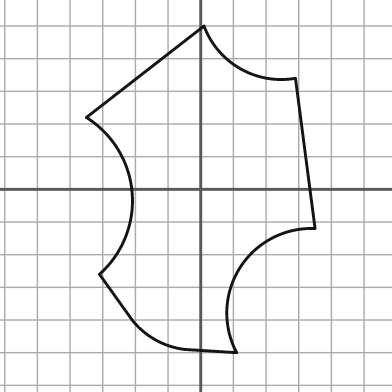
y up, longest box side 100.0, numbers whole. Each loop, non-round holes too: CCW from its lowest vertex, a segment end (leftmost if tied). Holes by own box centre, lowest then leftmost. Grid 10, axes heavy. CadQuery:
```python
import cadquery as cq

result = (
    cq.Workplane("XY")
    .moveTo(11.0, -50.0)
    .threePointArc((12.0, -24.0), (35.0, -12.0))
    .lineTo(29.0, 34.0)
    .threePointArc((12.0, 37.0), (1.0, 50.0))
    .lineTo(-35.0, 22.0)
    .threePointArc((-21.0, -1.0), (-31.0, -26.0))
    .lineTo(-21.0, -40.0)
    .threePointArc((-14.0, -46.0), (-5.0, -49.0))
    .close()
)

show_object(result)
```